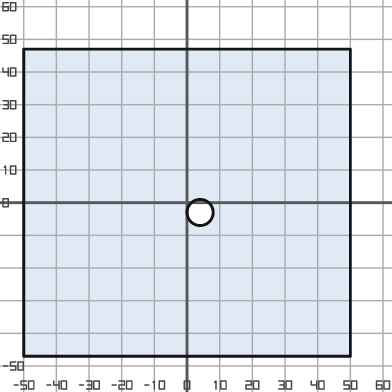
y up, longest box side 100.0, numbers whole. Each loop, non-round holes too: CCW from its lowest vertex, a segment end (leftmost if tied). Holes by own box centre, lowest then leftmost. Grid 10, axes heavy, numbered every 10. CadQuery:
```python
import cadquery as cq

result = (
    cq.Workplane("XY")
    .moveTo(-50.0, -47.0)
    .lineTo(50.0, -47.0)
    .lineTo(50.0, 47.0)
    .lineTo(-50.0, 47.0)
    .close()
    .moveTo(4.0, -3.0)
    .circle(4.0)
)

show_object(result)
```